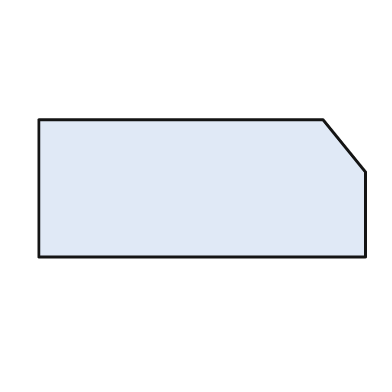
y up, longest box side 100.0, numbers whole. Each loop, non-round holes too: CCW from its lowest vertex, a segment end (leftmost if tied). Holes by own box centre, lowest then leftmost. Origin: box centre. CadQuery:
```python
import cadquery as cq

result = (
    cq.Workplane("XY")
    .moveTo(-50.0, -21.0)
    .lineTo(50.0, -21.0)
    .lineTo(50.0, 5.0)
    .lineTo(37.0, 21.0)
    .lineTo(-50.0, 21.0)
    .close()
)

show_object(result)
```